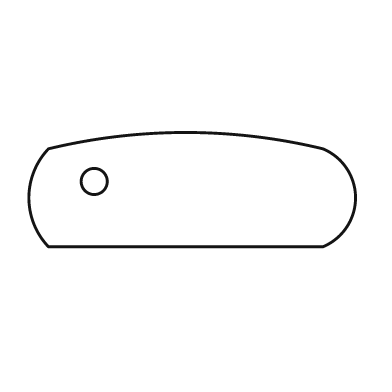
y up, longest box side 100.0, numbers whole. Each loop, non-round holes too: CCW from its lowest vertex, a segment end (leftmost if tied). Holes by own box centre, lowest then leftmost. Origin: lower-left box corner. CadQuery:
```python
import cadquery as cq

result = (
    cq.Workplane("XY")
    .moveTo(6.0, 0.0)
    .lineTo(90.0, 0.0)
    .threePointArc((100.0, 15.0), (90.0, 30.0))
    .threePointArc((48.0, 35.0), (6.0, 30.0))
    .threePointArc((0.0, 15.0), (6.0, 0.0))
    .close()
    .moveTo(20.0, 20.0)
    .circle(4.0)
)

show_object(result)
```